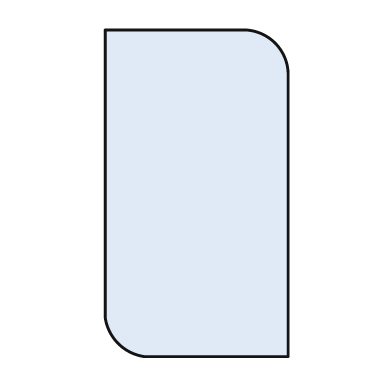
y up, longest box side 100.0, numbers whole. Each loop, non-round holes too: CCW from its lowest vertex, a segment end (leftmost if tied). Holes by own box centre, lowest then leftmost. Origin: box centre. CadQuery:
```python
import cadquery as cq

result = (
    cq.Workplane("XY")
    .moveTo(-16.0, -50.0)
    .lineTo(28.0, -50.0)
    .lineTo(28.0, 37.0)
    .threePointArc((24.0, 46.0), (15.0, 50.0))
    .lineTo(-28.0, 50.0)
    .lineTo(-28.0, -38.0)
    .threePointArc((-24.0, -46.0), (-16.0, -50.0))
    .close()
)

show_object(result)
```